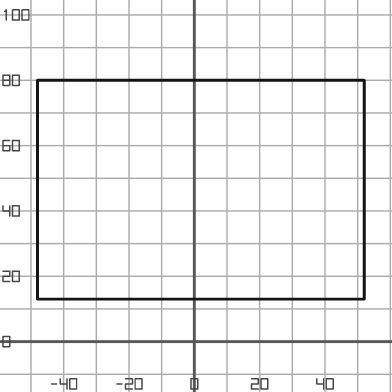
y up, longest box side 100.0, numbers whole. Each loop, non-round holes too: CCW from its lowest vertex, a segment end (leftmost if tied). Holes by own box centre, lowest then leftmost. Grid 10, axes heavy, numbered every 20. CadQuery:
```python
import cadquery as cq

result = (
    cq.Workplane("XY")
    .moveTo(-48.0, 13.0)
    .lineTo(52.0, 13.0)
    .lineTo(52.0, 80.0)
    .lineTo(-48.0, 80.0)
    .close()
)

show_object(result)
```